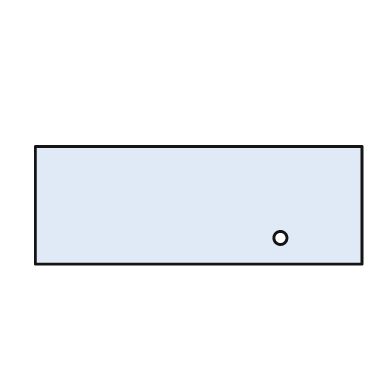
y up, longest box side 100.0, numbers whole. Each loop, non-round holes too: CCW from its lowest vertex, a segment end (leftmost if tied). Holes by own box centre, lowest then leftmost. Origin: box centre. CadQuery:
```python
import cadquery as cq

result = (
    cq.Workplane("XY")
    .moveTo(-50.0, -18.0)
    .lineTo(50.0, -18.0)
    .lineTo(50.0, 18.0)
    .lineTo(-50.0, 18.0)
    .close()
    .moveTo(25.0, -10.0)
    .circle(2.0)
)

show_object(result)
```